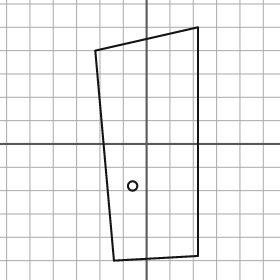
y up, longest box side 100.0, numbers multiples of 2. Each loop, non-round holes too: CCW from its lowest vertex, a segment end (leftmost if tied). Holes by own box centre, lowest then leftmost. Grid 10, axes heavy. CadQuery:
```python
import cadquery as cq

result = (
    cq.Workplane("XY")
    .moveTo(-14.0, -50.0)
    .lineTo(22.0, -48.0)
    .lineTo(22.0, 50.0)
    .lineTo(-22.0, 40.0)
    .close()
    .moveTo(-6.0, -18.0)
    .circle(2.0)
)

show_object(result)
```